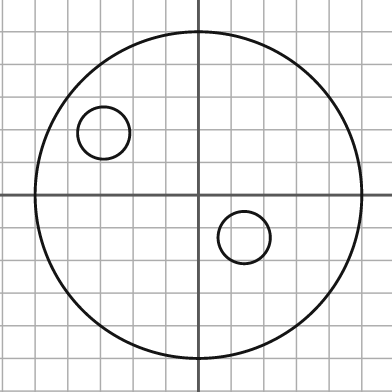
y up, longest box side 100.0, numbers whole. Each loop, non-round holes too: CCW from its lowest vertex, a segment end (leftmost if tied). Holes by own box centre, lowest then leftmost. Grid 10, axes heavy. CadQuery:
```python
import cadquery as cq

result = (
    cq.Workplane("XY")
    .moveTo(0.0, 0.0)
    .circle(50.0)
    .moveTo(14.0, -13.0)
    .circle(8.0)
    .moveTo(-29.0, 19.0)
    .circle(8.0)
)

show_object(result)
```